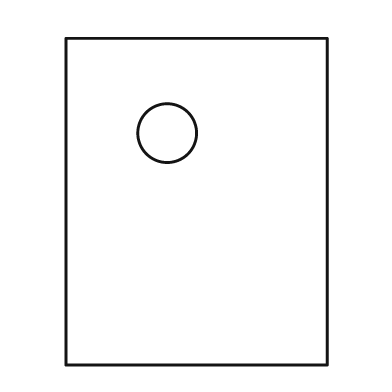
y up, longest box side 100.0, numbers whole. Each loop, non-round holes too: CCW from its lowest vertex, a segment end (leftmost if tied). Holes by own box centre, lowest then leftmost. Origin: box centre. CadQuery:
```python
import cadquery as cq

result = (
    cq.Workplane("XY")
    .moveTo(-40.0, -50.0)
    .lineTo(40.0, -50.0)
    .lineTo(40.0, 50.0)
    .lineTo(-40.0, 50.0)
    .close()
    .moveTo(-9.0, 21.0)
    .circle(9.0)
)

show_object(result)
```